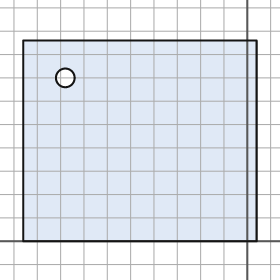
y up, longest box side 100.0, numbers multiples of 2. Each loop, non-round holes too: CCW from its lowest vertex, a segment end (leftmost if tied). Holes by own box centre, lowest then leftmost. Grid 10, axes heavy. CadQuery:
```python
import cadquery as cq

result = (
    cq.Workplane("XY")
    .moveTo(-96.0, 0.0)
    .lineTo(4.0, 0.0)
    .lineTo(4.0, 86.0)
    .lineTo(-96.0, 86.0)
    .close()
    .moveTo(-78.0, 70.0)
    .circle(4.0)
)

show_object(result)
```